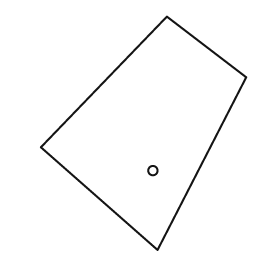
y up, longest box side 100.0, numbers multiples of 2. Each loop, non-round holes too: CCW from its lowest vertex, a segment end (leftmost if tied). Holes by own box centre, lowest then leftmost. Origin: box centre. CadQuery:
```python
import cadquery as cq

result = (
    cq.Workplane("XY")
    .moveTo(6.0, -50.0)
    .lineTo(44.0, 24.0)
    .lineTo(10.0, 50.0)
    .lineTo(-44.0, -6.0)
    .close()
    .moveTo(4.0, -16.0)
    .circle(2.0)
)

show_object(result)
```